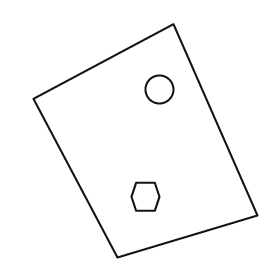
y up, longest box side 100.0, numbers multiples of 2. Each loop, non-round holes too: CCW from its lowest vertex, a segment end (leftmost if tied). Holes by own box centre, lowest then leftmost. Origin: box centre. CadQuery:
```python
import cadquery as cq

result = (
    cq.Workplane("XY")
    .moveTo(-12.0, -50.0)
    .lineTo(48.0, -32.0)
    .lineTo(12.0, 50.0)
    .lineTo(-48.0, 18.0)
    .close()
    .moveTo(-4.0, -30.0)
    .lineTo(4.0, -30.0)
    .lineTo(6.0, -24.0)
    .lineTo(4.0, -18.0)
    .lineTo(-4.0, -18.0)
    .lineTo(-6.0, -24.0)
    .close()
    .moveTo(6.0, 22.0)
    .circle(6.0)
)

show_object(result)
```